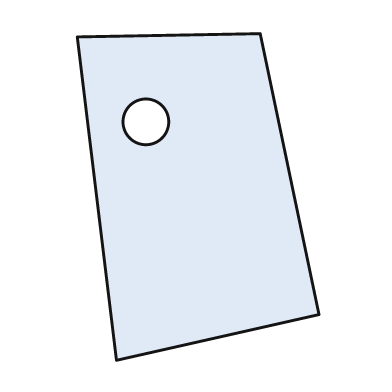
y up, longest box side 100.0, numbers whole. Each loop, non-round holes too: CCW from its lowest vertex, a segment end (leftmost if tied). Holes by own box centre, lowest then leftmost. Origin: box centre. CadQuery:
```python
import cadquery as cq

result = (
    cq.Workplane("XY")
    .moveTo(-25.0, -50.0)
    .lineTo(37.0, -36.0)
    .lineTo(19.0, 50.0)
    .lineTo(-37.0, 49.0)
    .close()
    .moveTo(-16.0, 23.0)
    .circle(7.0)
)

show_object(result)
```